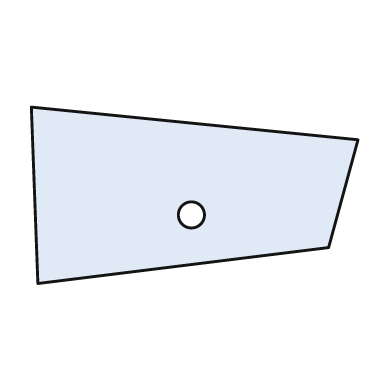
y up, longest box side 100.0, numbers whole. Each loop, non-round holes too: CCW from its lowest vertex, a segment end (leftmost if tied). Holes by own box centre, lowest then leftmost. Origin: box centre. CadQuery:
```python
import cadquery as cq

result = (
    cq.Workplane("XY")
    .moveTo(-48.0, -27.0)
    .lineTo(41.0, -16.0)
    .lineTo(50.0, 17.0)
    .lineTo(-50.0, 27.0)
    .close()
    .moveTo(-1.0, -6.0)
    .circle(4.0)
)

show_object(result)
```